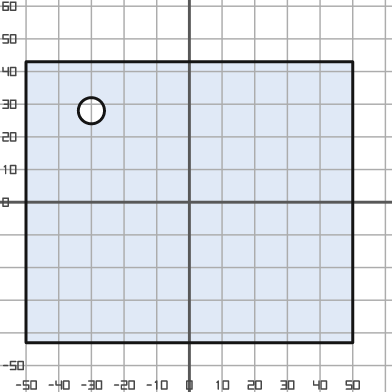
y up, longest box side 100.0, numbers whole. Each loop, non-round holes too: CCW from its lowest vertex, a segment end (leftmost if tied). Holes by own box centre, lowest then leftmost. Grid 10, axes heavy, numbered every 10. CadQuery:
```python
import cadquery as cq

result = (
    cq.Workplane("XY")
    .moveTo(-50.0, -43.0)
    .lineTo(50.0, -43.0)
    .lineTo(50.0, 43.0)
    .lineTo(-50.0, 43.0)
    .close()
    .moveTo(-30.0, 28.0)
    .circle(4.0)
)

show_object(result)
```